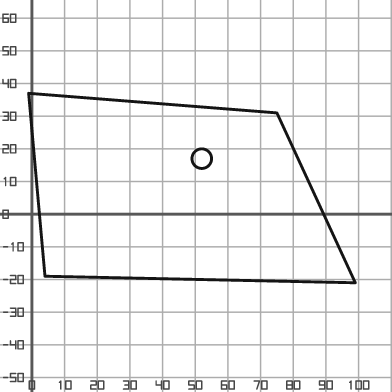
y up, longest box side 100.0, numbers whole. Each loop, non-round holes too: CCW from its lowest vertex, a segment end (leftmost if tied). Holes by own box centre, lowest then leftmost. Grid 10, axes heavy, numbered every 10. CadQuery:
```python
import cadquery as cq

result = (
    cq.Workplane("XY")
    .moveTo(99.0, -21.0)
    .lineTo(75.0, 31.0)
    .lineTo(-1.0, 37.0)
    .lineTo(4.0, -19.0)
    .close()
    .moveTo(52.0, 17.0)
    .circle(3.0)
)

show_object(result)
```